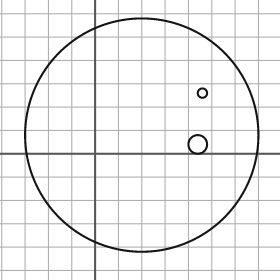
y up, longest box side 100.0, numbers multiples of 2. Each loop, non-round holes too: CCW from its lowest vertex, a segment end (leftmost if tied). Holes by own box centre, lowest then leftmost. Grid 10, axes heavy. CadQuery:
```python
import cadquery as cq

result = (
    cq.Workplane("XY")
    .moveTo(20.0, 8.0)
    .circle(50.0)
    .moveTo(44.0, 4.0)
    .circle(4.0)
    .moveTo(46.0, 26.0)
    .circle(2.0)
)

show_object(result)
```